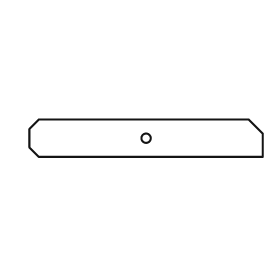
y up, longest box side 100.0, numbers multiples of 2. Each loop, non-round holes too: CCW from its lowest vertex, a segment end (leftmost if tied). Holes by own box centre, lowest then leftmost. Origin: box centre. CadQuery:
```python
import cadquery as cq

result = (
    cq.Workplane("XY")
    .moveTo(-46.0, -8.0)
    .lineTo(50.0, -8.0)
    .lineTo(50.0, 2.0)
    .lineTo(44.0, 8.0)
    .lineTo(-46.0, 8.0)
    .lineTo(-50.0, 4.0)
    .lineTo(-50.0, -4.0)
    .close()
    .moveTo(0.0, 0.0)
    .circle(2.0)
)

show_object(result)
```